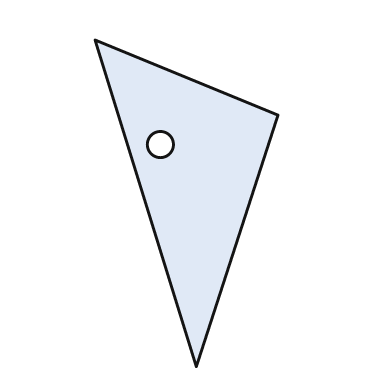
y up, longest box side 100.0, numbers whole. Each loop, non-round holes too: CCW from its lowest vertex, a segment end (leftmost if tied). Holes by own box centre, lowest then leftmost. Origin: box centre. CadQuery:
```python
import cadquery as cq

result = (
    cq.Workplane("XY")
    .moveTo(3.0, -50.0)
    .lineTo(28.0, 27.0)
    .lineTo(-28.0, 50.0)
    .close()
    .moveTo(-8.0, 18.0)
    .circle(4.0)
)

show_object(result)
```